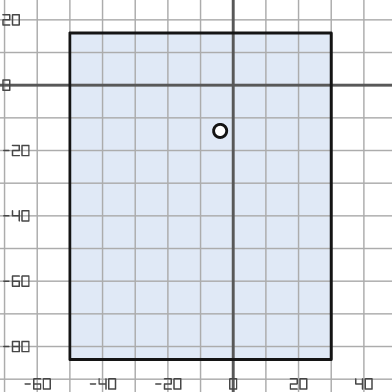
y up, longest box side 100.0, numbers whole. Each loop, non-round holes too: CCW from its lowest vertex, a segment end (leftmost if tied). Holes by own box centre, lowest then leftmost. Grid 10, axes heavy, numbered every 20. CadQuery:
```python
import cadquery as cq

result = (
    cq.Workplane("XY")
    .moveTo(-50.0, -84.0)
    .lineTo(30.0, -84.0)
    .lineTo(30.0, 16.0)
    .lineTo(-50.0, 16.0)
    .close()
    .moveTo(-4.0, -14.0)
    .circle(2.0)
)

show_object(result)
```